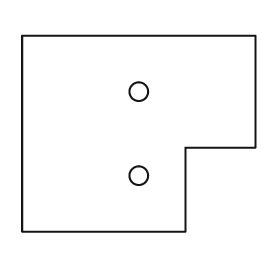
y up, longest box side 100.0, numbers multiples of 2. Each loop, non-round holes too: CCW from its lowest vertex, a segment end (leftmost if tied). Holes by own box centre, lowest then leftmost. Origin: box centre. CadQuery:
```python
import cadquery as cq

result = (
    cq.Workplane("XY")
    .moveTo(-50.0, -42.0)
    .lineTo(20.0, -42.0)
    .lineTo(20.0, -6.0)
    .lineTo(50.0, -6.0)
    .lineTo(50.0, 42.0)
    .lineTo(-50.0, 42.0)
    .close()
    .moveTo(0.0, -18.0)
    .circle(4.0)
    .moveTo(0.0, 18.0)
    .circle(4.0)
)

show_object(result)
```